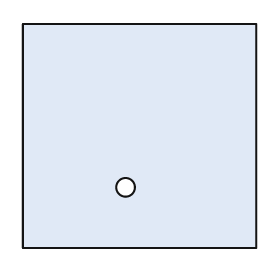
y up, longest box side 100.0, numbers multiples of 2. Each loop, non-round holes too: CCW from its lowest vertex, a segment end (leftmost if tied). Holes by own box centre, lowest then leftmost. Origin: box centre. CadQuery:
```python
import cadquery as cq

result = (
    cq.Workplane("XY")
    .moveTo(-50.0, -48.0)
    .lineTo(50.0, -48.0)
    .lineTo(50.0, 48.0)
    .lineTo(-50.0, 48.0)
    .close()
    .moveTo(-6.0, -22.0)
    .circle(4.0)
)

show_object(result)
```